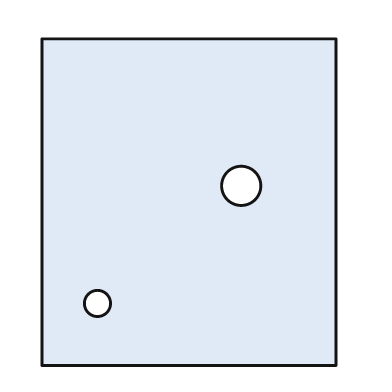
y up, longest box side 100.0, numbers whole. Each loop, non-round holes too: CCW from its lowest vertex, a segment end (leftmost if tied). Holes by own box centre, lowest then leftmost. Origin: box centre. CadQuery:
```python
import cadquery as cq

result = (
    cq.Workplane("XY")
    .moveTo(-45.0, -50.0)
    .lineTo(45.0, -50.0)
    .lineTo(45.0, 50.0)
    .lineTo(-45.0, 50.0)
    .close()
    .moveTo(-28.0, -31.0)
    .circle(4.0)
    .moveTo(16.0, 5.0)
    .circle(6.0)
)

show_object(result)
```